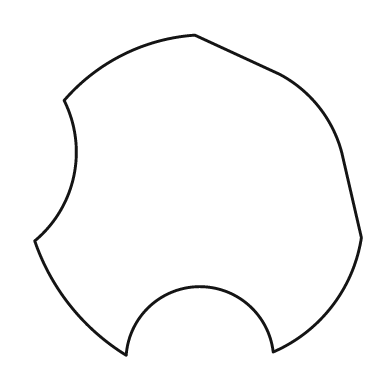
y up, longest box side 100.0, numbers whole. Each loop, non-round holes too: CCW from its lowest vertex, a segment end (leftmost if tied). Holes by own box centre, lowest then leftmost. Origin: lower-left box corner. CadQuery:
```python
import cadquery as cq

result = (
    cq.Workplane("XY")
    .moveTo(28.0, 0.0)
    .threePointArc((50.0, 21.0), (73.0, 1.0))
    .threePointArc((91.0, 15.0), (100.0, 36.0))
    .lineTo(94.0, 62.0)
    .threePointArc((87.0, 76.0), (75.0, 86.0))
    .lineTo(49.0, 98.0)
    .threePointArc((27.0, 92.0), (9.0, 78.0))
    .threePointArc((12.0, 55.0), (0.0, 35.0))
    .threePointArc((11.0, 15.0), (28.0, 0.0))
    .close()
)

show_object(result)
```